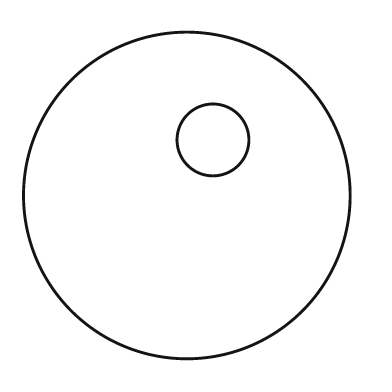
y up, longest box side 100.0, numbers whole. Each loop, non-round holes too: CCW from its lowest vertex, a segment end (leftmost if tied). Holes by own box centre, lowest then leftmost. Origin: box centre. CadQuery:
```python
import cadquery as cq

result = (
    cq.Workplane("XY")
    .moveTo(0.0, 0.0)
    .circle(50.0)
    .moveTo(8.0, 17.0)
    .circle(11.0)
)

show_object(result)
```